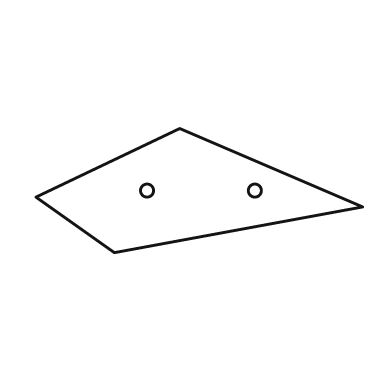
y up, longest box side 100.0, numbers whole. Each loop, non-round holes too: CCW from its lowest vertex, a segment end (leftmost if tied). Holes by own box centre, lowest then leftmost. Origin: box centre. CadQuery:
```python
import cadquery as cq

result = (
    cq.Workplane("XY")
    .moveTo(-26.0, -19.0)
    .lineTo(50.0, -5.0)
    .lineTo(-6.0, 19.0)
    .lineTo(-50.0, -2.0)
    .close()
    .moveTo(-16.0, 0.0)
    .circle(2.0)
    .moveTo(17.0, 0.0)
    .circle(2.0)
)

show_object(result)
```